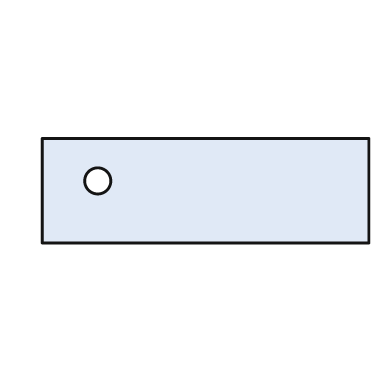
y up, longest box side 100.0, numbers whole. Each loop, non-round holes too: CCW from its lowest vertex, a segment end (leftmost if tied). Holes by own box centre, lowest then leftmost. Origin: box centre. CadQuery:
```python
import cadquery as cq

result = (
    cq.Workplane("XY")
    .moveTo(-50.0, -16.0)
    .lineTo(50.0, -16.0)
    .lineTo(50.0, 16.0)
    .lineTo(-50.0, 16.0)
    .close()
    .moveTo(-33.0, 3.0)
    .circle(4.0)
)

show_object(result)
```